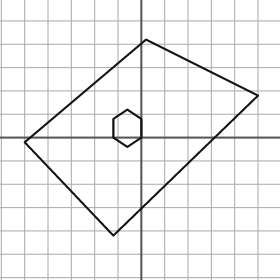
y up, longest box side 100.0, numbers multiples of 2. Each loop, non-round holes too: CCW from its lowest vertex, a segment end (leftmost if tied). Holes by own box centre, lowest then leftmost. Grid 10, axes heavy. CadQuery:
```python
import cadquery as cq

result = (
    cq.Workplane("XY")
    .moveTo(-12.0, -42.0)
    .lineTo(50.0, 18.0)
    .lineTo(2.0, 42.0)
    .lineTo(-50.0, -2.0)
    .close()
    .moveTo(-6.0, -4.0)
    .lineTo(0.0, 0.0)
    .lineTo(0.0, 8.0)
    .lineTo(-6.0, 12.0)
    .lineTo(-12.0, 8.0)
    .lineTo(-12.0, 0.0)
    .close()
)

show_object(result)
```